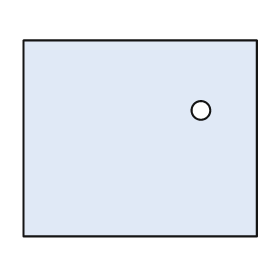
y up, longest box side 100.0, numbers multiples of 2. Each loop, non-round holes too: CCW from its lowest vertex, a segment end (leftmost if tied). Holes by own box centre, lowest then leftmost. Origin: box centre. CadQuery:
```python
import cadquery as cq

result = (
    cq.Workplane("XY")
    .moveTo(-50.0, -42.0)
    .lineTo(50.0, -42.0)
    .lineTo(50.0, 42.0)
    .lineTo(-50.0, 42.0)
    .close()
    .moveTo(26.0, 12.0)
    .circle(4.0)
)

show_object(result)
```